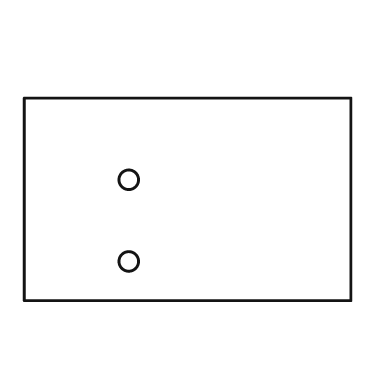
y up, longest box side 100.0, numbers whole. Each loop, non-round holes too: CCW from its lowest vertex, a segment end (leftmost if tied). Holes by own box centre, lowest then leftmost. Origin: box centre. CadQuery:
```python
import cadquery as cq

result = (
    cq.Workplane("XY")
    .moveTo(-50.0, -31.0)
    .lineTo(50.0, -31.0)
    .lineTo(50.0, 31.0)
    .lineTo(-50.0, 31.0)
    .close()
    .moveTo(-18.0, -19.0)
    .circle(3.0)
    .moveTo(-18.0, 6.0)
    .circle(3.0)
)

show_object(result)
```